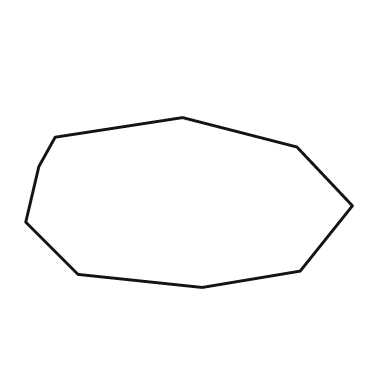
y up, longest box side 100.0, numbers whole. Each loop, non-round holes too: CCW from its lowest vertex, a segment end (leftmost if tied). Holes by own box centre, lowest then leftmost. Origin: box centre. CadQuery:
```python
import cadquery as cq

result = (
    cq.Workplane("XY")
    .moveTo(4.0, -26.0)
    .lineTo(34.0, -21.0)
    .lineTo(50.0, -1.0)
    .lineTo(33.0, 17.0)
    .lineTo(-2.0, 26.0)
    .lineTo(-41.0, 20.0)
    .lineTo(-46.0, 11.0)
    .lineTo(-50.0, -6.0)
    .lineTo(-34.0, -22.0)
    .close()
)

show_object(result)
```